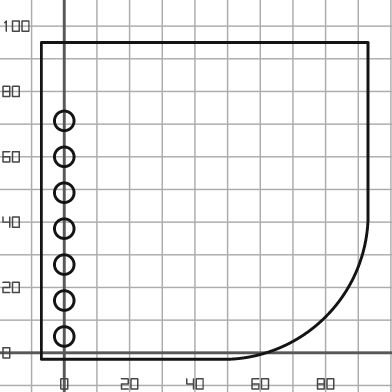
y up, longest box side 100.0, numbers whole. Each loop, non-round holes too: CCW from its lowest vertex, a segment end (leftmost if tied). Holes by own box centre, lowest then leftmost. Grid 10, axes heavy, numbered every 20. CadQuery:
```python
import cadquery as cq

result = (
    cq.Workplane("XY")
    .moveTo(-7.0, -2.0)
    .lineTo(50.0, -2.0)
    .threePointArc((80.0, 11.0), (93.0, 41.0))
    .lineTo(93.0, 95.0)
    .lineTo(-7.0, 95.0)
    .close()
    .moveTo(0.0, 5.0)
    .circle(3.0)
    .moveTo(0.0, 16.0)
    .circle(3.0)
    .moveTo(0.0, 27.0)
    .circle(3.0)
    .moveTo(0.0, 38.0)
    .circle(3.0)
    .moveTo(0.0, 49.0)
    .circle(3.0)
    .moveTo(0.0, 60.0)
    .circle(3.0)
    .moveTo(0.0, 71.0)
    .circle(3.0)
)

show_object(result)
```